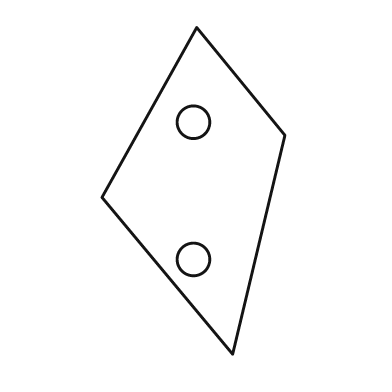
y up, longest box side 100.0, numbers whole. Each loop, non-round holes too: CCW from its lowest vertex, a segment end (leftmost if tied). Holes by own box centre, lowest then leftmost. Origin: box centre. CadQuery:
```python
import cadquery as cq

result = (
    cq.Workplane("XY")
    .moveTo(12.0, -50.0)
    .lineTo(28.0, 17.0)
    .lineTo(1.0, 50.0)
    .lineTo(-28.0, -2.0)
    .close()
    .moveTo(0.0, -21.0)
    .circle(5.0)
    .moveTo(0.0, 21.0)
    .circle(5.0)
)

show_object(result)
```